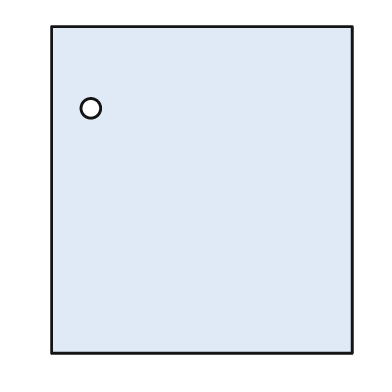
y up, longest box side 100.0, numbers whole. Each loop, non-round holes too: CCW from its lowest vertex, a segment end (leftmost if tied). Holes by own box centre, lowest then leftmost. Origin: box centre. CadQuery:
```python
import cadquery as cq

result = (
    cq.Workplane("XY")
    .moveTo(-46.0, -50.0)
    .lineTo(46.0, -50.0)
    .lineTo(46.0, 50.0)
    .lineTo(-46.0, 50.0)
    .close()
    .moveTo(-34.0, 25.0)
    .circle(3.0)
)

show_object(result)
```